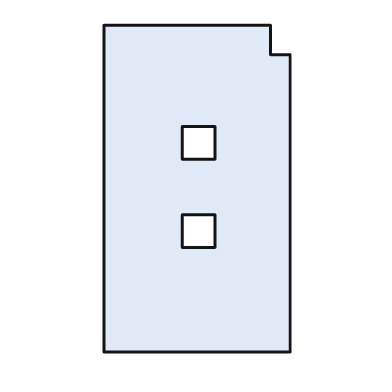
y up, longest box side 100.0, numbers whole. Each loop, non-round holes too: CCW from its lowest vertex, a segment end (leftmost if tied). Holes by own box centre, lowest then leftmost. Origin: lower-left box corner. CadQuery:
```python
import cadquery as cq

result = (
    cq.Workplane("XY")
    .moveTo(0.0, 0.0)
    .lineTo(57.0, 0.0)
    .lineTo(57.0, 91.0)
    .lineTo(51.0, 91.0)
    .lineTo(51.0, 100.0)
    .lineTo(0.0, 100.0)
    .close()
    .moveTo(24.0, 32.0)
    .lineTo(34.0, 32.0)
    .lineTo(34.0, 42.0)
    .lineTo(24.0, 42.0)
    .close()
    .moveTo(24.0, 59.0)
    .lineTo(34.0, 59.0)
    .lineTo(34.0, 69.0)
    .lineTo(24.0, 69.0)
    .close()
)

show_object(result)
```